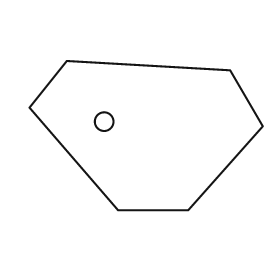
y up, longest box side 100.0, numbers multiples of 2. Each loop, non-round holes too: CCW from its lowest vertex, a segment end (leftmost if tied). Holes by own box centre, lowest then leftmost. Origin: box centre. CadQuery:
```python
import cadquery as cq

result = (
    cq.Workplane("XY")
    .moveTo(-12.0, -32.0)
    .lineTo(18.0, -32.0)
    .lineTo(50.0, 4.0)
    .lineTo(36.0, 28.0)
    .lineTo(-34.0, 32.0)
    .lineTo(-50.0, 12.0)
    .close()
    .moveTo(-18.0, 6.0)
    .circle(4.0)
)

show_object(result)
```